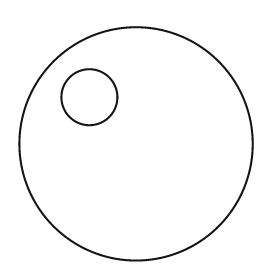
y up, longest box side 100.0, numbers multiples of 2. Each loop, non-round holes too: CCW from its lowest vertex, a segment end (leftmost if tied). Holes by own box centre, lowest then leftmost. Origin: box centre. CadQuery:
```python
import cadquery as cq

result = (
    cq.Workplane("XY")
    .moveTo(0.0, 0.0)
    .circle(50.0)
    .moveTo(-20.0, 20.0)
    .circle(12.0)
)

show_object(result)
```